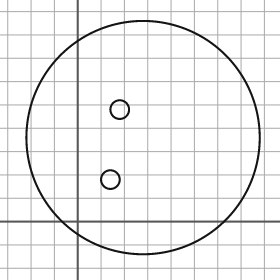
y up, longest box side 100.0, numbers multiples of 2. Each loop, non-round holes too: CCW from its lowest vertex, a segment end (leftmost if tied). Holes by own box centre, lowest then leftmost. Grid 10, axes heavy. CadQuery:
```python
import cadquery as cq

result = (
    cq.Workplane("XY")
    .moveTo(28.0, 36.0)
    .circle(50.0)
    .moveTo(14.0, 18.0)
    .circle(4.0)
    .moveTo(18.0, 48.0)
    .circle(4.0)
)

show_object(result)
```